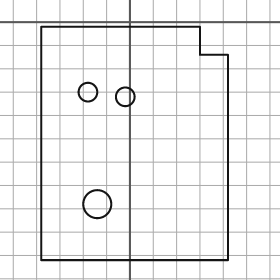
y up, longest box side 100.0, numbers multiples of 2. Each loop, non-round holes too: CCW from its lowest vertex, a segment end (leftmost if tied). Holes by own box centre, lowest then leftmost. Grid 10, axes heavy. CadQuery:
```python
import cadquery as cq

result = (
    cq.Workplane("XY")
    .moveTo(-38.0, -102.0)
    .lineTo(42.0, -102.0)
    .lineTo(42.0, -14.0)
    .lineTo(30.0, -14.0)
    .lineTo(30.0, -2.0)
    .lineTo(-38.0, -2.0)
    .close()
    .moveTo(-14.0, -78.0)
    .circle(6.0)
    .moveTo(-2.0, -32.0)
    .circle(4.0)
    .moveTo(-18.0, -30.0)
    .circle(4.0)
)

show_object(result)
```